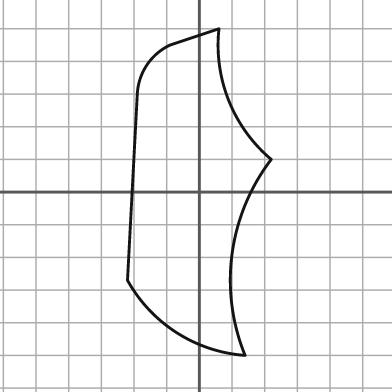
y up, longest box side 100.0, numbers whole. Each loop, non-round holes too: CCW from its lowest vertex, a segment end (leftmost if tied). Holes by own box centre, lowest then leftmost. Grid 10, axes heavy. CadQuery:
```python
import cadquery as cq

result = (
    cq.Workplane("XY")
    .moveTo(14.0, -50.0)
    .threePointArc((10.0, -19.0), (22.0, 10.0))
    .threePointArc((9.0, 28.0), (6.0, 50.0))
    .lineTo(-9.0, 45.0)
    .threePointArc((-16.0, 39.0), (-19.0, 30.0))
    .lineTo(-22.0, -27.0)
    .threePointArc((-7.0, -43.0), (14.0, -50.0))
    .close()
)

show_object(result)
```